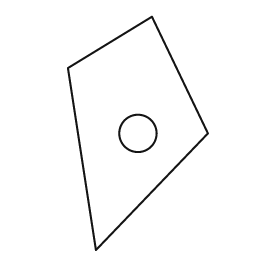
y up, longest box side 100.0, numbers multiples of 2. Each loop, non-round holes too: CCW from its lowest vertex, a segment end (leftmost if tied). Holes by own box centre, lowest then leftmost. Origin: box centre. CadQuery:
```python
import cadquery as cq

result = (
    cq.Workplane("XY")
    .moveTo(-18.0, -50.0)
    .lineTo(30.0, 0.0)
    .lineTo(6.0, 50.0)
    .lineTo(-30.0, 28.0)
    .close()
    .moveTo(0.0, 0.0)
    .circle(8.0)
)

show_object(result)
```